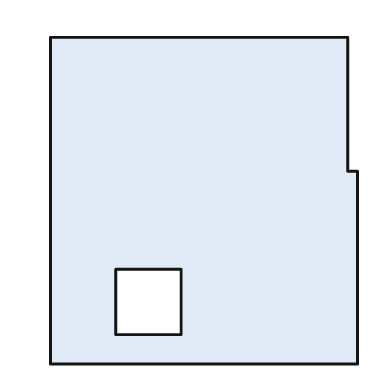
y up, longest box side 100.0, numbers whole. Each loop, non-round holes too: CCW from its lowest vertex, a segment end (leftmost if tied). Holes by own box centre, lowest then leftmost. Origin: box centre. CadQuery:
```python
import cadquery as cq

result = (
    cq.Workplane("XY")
    .moveTo(-47.0, -50.0)
    .lineTo(47.0, -50.0)
    .lineTo(47.0, 9.0)
    .lineTo(44.0, 9.0)
    .lineTo(44.0, 50.0)
    .lineTo(-47.0, 50.0)
    .close()
    .moveTo(-27.0, -41.0)
    .lineTo(-7.0, -41.0)
    .lineTo(-7.0, -21.0)
    .lineTo(-27.0, -21.0)
    .close()
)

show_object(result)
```